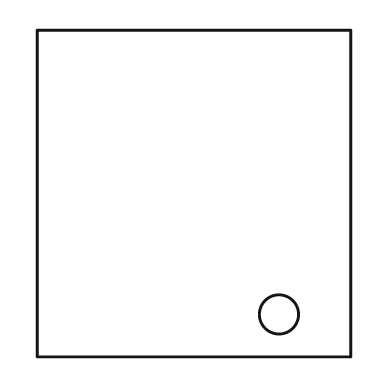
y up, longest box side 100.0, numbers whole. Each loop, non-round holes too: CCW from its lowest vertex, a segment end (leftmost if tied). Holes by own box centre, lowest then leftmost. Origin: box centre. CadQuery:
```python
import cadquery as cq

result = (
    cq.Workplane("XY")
    .moveTo(-48.0, -50.0)
    .lineTo(48.0, -50.0)
    .lineTo(48.0, 50.0)
    .lineTo(-48.0, 50.0)
    .close()
    .moveTo(26.0, -37.0)
    .circle(6.0)
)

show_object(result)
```